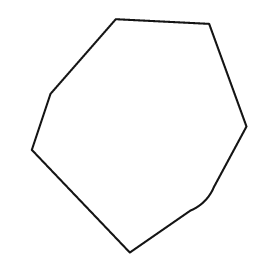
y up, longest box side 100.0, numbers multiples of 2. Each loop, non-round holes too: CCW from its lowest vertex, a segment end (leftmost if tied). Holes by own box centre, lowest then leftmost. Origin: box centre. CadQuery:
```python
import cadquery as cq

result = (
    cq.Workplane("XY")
    .moveTo(-4.0, -50.0)
    .lineTo(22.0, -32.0)
    .threePointArc((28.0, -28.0), (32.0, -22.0))
    .lineTo(46.0, 4.0)
    .lineTo(30.0, 48.0)
    .lineTo(-10.0, 50.0)
    .lineTo(-38.0, 18.0)
    .lineTo(-46.0, -6.0)
    .close()
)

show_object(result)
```